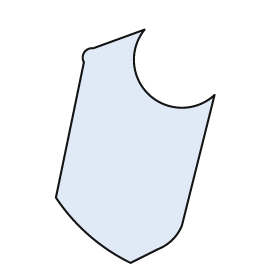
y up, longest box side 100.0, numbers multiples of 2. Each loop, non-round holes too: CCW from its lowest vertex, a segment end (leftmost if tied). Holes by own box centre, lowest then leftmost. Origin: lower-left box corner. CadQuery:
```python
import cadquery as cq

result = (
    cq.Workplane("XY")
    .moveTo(32.0, 0.0)
    .lineTo(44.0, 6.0)
    .threePointArc((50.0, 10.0), (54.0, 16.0))
    .lineTo(68.0, 72.0)
    .threePointArc((40.0, 72.0), (38.0, 100.0))
    .lineTo(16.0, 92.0)
    .threePointArc((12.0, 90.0), (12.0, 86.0))
    .lineTo(0.0, 28.0)
    .threePointArc((14.0, 12.0), (32.0, 0.0))
    .close()
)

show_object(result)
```